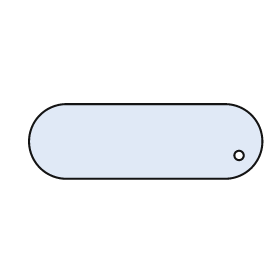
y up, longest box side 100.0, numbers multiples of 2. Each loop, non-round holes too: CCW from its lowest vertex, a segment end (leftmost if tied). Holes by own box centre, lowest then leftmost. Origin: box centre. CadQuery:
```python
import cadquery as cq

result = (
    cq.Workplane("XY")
    .moveTo(-34.0, -16.0)
    .lineTo(34.0, -16.0)
    .threePointArc((50.0, 0.0), (34.0, 16.0))
    .lineTo(-34.0, 16.0)
    .threePointArc((-50.0, 0.0), (-34.0, -16.0))
    .close()
    .moveTo(40.0, -6.0)
    .circle(2.0)
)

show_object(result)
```